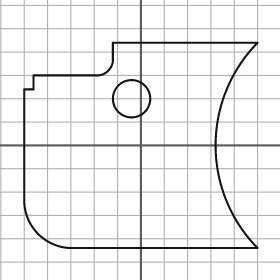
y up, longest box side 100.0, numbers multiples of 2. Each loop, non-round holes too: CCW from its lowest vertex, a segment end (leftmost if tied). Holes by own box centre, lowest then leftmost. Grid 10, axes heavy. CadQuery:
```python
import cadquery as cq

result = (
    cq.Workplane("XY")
    .moveTo(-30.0, -44.0)
    .lineTo(50.0, -44.0)
    .threePointArc((32.0, 0.0), (50.0, 44.0))
    .lineTo(-12.0, 44.0)
    .lineTo(-12.0, 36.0)
    .threePointArc((-14.0, 32.0), (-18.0, 30.0))
    .lineTo(-46.0, 30.0)
    .lineTo(-46.0, 24.0)
    .lineTo(-50.0, 24.0)
    .lineTo(-50.0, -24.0)
    .threePointArc((-44.0, -38.0), (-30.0, -44.0))
    .close()
    .moveTo(-4.0, 20.0)
    .circle(8.0)
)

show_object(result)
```